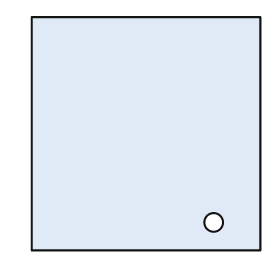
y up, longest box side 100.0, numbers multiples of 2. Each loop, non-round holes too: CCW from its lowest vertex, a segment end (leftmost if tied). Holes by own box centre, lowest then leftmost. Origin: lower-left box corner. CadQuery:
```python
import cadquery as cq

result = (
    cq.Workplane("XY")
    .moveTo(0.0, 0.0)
    .lineTo(98.0, 0.0)
    .lineTo(98.0, 100.0)
    .lineTo(0.0, 100.0)
    .close()
    .moveTo(78.0, 12.0)
    .circle(4.0)
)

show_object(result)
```